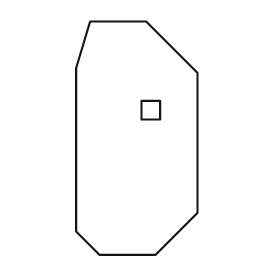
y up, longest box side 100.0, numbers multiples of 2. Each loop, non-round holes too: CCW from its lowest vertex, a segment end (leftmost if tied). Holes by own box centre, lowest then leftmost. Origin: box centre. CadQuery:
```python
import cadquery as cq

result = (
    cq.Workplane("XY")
    .moveTo(-16.0, -50.0)
    .lineTo(8.0, -50.0)
    .lineTo(26.0, -32.0)
    .lineTo(26.0, 28.0)
    .lineTo(4.0, 50.0)
    .lineTo(-20.0, 50.0)
    .lineTo(-26.0, 30.0)
    .lineTo(-26.0, -40.0)
    .close()
    .moveTo(2.0, 8.0)
    .lineTo(10.0, 8.0)
    .lineTo(10.0, 16.0)
    .lineTo(2.0, 16.0)
    .close()
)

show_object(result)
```